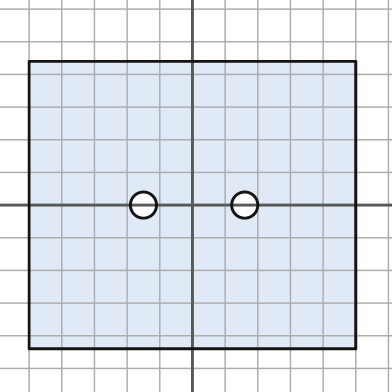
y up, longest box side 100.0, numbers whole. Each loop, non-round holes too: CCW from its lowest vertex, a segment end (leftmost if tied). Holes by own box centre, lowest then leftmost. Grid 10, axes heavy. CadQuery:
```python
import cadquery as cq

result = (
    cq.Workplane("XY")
    .moveTo(-50.0, -44.0)
    .lineTo(50.0, -44.0)
    .lineTo(50.0, 44.0)
    .lineTo(-50.0, 44.0)
    .close()
    .moveTo(-15.0, 0.0)
    .circle(4.0)
    .moveTo(16.0, 0.0)
    .circle(4.0)
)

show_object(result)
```